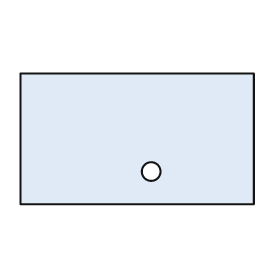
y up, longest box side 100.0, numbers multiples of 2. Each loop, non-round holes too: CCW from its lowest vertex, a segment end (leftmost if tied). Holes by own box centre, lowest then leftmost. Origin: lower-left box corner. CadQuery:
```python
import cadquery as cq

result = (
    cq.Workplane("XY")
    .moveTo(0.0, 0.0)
    .lineTo(100.0, 0.0)
    .lineTo(100.0, 56.0)
    .lineTo(0.0, 56.0)
    .close()
    .moveTo(56.0, 14.0)
    .circle(4.0)
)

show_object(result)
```